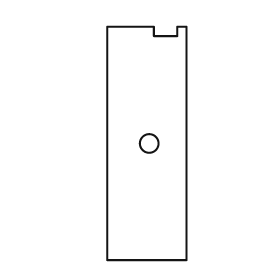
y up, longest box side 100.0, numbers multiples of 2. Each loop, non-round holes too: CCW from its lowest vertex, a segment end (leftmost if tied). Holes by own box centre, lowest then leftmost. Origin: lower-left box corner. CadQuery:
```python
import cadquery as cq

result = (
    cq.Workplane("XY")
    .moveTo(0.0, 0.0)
    .lineTo(34.0, 0.0)
    .lineTo(34.0, 100.0)
    .lineTo(30.0, 100.0)
    .lineTo(30.0, 96.0)
    .lineTo(20.0, 96.0)
    .lineTo(20.0, 100.0)
    .lineTo(0.0, 100.0)
    .close()
    .moveTo(18.0, 50.0)
    .circle(4.0)
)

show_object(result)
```